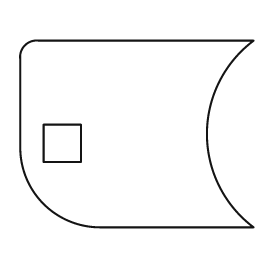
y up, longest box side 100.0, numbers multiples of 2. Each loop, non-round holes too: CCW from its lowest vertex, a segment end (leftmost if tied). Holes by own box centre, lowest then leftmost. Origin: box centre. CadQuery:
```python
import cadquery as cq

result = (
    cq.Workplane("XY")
    .moveTo(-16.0, -40.0)
    .lineTo(50.0, -40.0)
    .threePointArc((30.0, 0.0), (50.0, 40.0))
    .lineTo(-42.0, 40.0)
    .threePointArc((-48.0, 38.0), (-50.0, 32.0))
    .lineTo(-50.0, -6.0)
    .threePointArc((-40.0, -30.0), (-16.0, -40.0))
    .close()
    .moveTo(-40.0, -12.0)
    .lineTo(-24.0, -12.0)
    .lineTo(-24.0, 4.0)
    .lineTo(-40.0, 4.0)
    .close()
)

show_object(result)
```